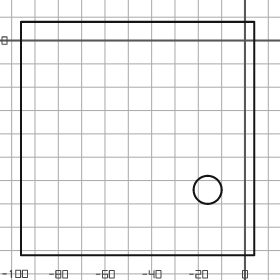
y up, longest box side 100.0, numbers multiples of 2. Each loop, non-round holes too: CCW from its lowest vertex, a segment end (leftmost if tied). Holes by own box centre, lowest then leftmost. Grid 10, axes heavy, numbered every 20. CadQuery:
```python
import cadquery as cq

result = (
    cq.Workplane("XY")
    .moveTo(-96.0, -92.0)
    .lineTo(4.0, -92.0)
    .lineTo(4.0, 8.0)
    .lineTo(-96.0, 8.0)
    .close()
    .moveTo(-16.0, -64.0)
    .circle(6.0)
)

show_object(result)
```